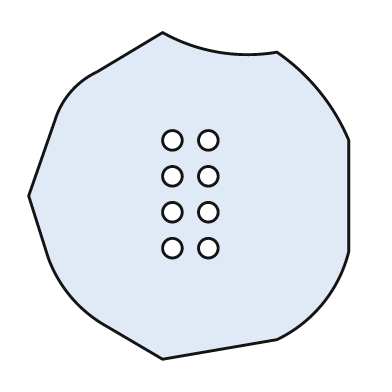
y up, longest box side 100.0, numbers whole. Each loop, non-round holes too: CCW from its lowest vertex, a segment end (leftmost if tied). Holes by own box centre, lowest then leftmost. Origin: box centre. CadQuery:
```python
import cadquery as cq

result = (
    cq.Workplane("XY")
    .moveTo(-8.0, -50.0)
    .lineTo(27.0, -44.0)
    .threePointArc((41.0, -33.0), (49.0, -17.0))
    .lineTo(49.0, 17.0)
    .threePointArc((40.0, 32.0), (27.0, 44.0))
    .threePointArc((9.0, 44.0), (-8.0, 50.0))
    .lineTo(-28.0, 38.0)
    .threePointArc((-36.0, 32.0), (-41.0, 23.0))
    .lineTo(-49.0, 0.0)
    .lineTo(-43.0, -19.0)
    .threePointArc((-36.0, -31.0), (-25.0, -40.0))
    .close()
    .moveTo(-5.0, -16.0)
    .circle(3.0)
    .moveTo(6.0, -16.0)
    .circle(3.0)
    .moveTo(-5.0, -5.0)
    .circle(3.0)
    .moveTo(6.0, -5.0)
    .circle(3.0)
    .moveTo(-5.0, 6.0)
    .circle(3.0)
    .moveTo(6.0, 6.0)
    .circle(3.0)
    .moveTo(-5.0, 17.0)
    .circle(3.0)
    .moveTo(6.0, 17.0)
    .circle(3.0)
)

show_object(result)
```